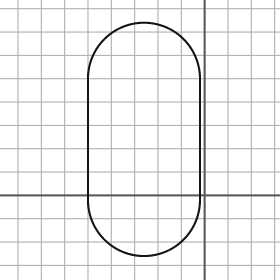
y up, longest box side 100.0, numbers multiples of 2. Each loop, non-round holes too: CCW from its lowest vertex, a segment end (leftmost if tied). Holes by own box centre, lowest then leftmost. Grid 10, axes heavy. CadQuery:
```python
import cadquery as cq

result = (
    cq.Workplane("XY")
    .moveTo(-50.0, -2.0)
    .threePointArc((-26.0, -26.0), (-2.0, -2.0))
    .lineTo(-2.0, 50.0)
    .threePointArc((-26.0, 74.0), (-50.0, 50.0))
    .close()
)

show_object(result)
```